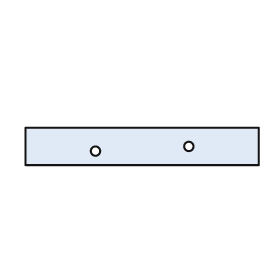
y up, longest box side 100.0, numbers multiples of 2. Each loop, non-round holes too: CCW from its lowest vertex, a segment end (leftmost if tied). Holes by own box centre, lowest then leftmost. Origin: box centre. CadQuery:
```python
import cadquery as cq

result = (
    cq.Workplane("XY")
    .moveTo(-50.0, -8.0)
    .lineTo(50.0, -8.0)
    .lineTo(50.0, 8.0)
    .lineTo(-50.0, 8.0)
    .close()
    .moveTo(-20.0, -2.0)
    .circle(2.0)
    .moveTo(20.0, 0.0)
    .circle(2.0)
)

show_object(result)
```